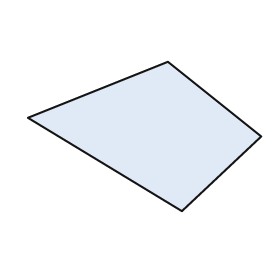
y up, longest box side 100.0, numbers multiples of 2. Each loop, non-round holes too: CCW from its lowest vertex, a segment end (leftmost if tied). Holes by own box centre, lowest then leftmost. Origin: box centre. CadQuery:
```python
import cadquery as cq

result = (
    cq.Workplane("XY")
    .moveTo(16.0, -32.0)
    .lineTo(50.0, 0.0)
    .lineTo(10.0, 32.0)
    .lineTo(-50.0, 8.0)
    .close()
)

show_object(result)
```